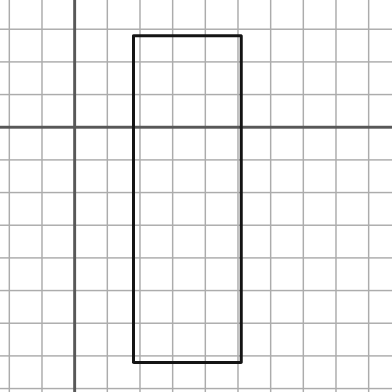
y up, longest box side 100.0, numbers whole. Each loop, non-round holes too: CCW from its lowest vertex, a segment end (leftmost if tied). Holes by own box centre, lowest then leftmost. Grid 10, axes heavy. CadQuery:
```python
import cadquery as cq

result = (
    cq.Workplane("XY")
    .moveTo(18.0, -72.0)
    .lineTo(51.0, -72.0)
    .lineTo(51.0, 28.0)
    .lineTo(18.0, 28.0)
    .close()
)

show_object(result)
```